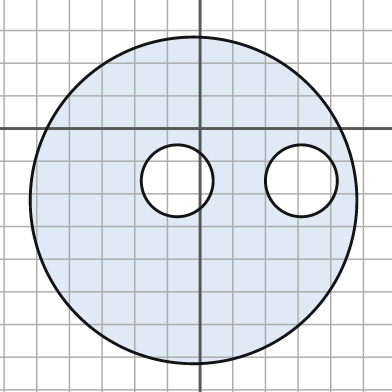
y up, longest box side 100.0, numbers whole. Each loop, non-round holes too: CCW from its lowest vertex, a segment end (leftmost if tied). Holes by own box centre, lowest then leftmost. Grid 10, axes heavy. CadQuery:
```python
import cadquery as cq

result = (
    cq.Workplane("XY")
    .moveTo(-2.0, -22.0)
    .circle(50.0)
    .moveTo(-7.0, -16.0)
    .circle(11.0)
    .moveTo(31.0, -16.0)
    .circle(11.0)
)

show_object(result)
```